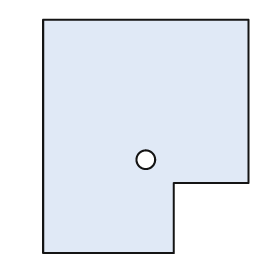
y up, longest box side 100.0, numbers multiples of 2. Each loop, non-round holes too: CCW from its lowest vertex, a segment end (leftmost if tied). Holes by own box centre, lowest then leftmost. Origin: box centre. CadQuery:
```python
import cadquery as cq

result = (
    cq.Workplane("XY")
    .moveTo(-44.0, -50.0)
    .lineTo(12.0, -50.0)
    .lineTo(12.0, -20.0)
    .lineTo(44.0, -20.0)
    .lineTo(44.0, 50.0)
    .lineTo(-44.0, 50.0)
    .close()
    .moveTo(0.0, -10.0)
    .circle(4.0)
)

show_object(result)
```